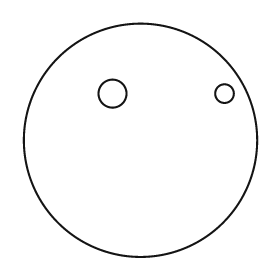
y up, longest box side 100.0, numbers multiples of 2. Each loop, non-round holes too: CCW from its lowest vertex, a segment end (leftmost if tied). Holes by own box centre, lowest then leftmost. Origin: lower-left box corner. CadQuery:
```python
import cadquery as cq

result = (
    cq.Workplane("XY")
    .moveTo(50.0, 50.0)
    .circle(50.0)
    .moveTo(38.0, 70.0)
    .circle(6.0)
    .moveTo(86.0, 70.0)
    .circle(4.0)
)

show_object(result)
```